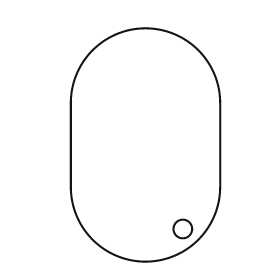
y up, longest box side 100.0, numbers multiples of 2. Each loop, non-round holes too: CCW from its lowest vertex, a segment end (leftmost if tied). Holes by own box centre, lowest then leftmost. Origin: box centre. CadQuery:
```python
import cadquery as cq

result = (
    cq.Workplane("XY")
    .moveTo(-32.0, -18.0)
    .threePointArc((0.0, -50.0), (32.0, -18.0))
    .lineTo(32.0, 18.0)
    .threePointArc((0.0, 50.0), (-32.0, 18.0))
    .close()
    .moveTo(16.0, -36.0)
    .circle(4.0)
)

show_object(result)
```